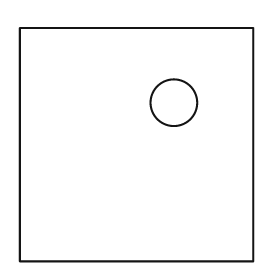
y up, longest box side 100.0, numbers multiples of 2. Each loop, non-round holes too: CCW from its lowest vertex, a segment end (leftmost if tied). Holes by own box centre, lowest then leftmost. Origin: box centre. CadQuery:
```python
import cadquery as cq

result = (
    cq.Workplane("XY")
    .moveTo(-50.0, -50.0)
    .lineTo(50.0, -50.0)
    .lineTo(50.0, 50.0)
    .lineTo(-50.0, 50.0)
    .close()
    .moveTo(16.0, 18.0)
    .circle(10.0)
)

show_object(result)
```